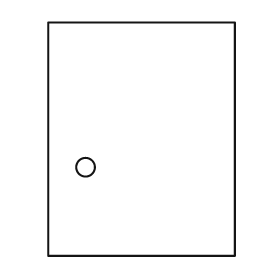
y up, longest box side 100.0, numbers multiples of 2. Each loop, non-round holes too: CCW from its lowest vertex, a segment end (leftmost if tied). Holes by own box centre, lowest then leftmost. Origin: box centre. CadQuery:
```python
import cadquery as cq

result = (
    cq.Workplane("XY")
    .moveTo(-40.0, -50.0)
    .lineTo(40.0, -50.0)
    .lineTo(40.0, 50.0)
    .lineTo(-40.0, 50.0)
    .close()
    .moveTo(-24.0, -12.0)
    .circle(4.0)
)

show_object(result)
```